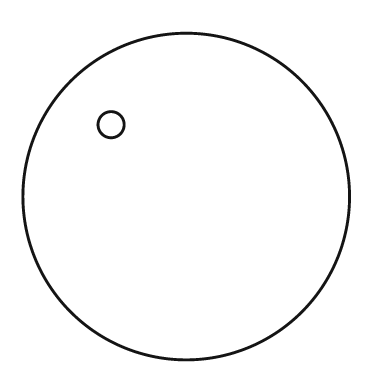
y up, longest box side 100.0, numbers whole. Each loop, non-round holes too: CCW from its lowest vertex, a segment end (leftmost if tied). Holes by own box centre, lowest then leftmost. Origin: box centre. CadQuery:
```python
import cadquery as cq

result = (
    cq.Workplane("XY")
    .moveTo(0.0, 0.0)
    .circle(50.0)
    .moveTo(-23.0, 22.0)
    .circle(4.0)
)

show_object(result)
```